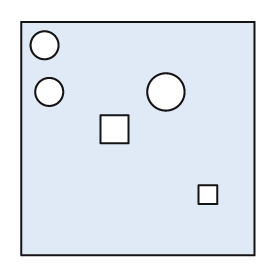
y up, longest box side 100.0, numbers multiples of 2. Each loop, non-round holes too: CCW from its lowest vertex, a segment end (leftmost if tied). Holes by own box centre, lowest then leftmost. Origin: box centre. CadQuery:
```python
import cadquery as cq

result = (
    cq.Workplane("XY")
    .moveTo(-50.0, -50.0)
    .lineTo(50.0, -50.0)
    .lineTo(50.0, 50.0)
    .lineTo(-50.0, 50.0)
    .close()
    .moveTo(26.0, -28.0)
    .lineTo(34.0, -28.0)
    .lineTo(34.0, -20.0)
    .lineTo(26.0, -20.0)
    .close()
    .moveTo(-16.0, -2.0)
    .lineTo(-4.0, -2.0)
    .lineTo(-4.0, 10.0)
    .lineTo(-16.0, 10.0)
    .close()
    .moveTo(-38.0, 20.0)
    .circle(6.0)
    .moveTo(12.0, 20.0)
    .circle(8.0)
    .moveTo(-40.0, 40.0)
    .circle(6.0)
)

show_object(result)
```